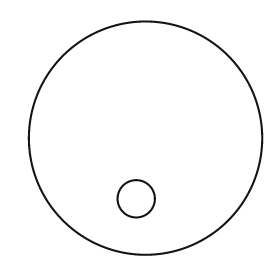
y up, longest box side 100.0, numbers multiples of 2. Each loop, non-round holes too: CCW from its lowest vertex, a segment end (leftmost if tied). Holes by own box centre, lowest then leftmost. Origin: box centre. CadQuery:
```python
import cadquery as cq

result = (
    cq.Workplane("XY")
    .moveTo(0.0, 0.0)
    .circle(50.0)
    .moveTo(-4.0, -26.0)
    .circle(8.0)
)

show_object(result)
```